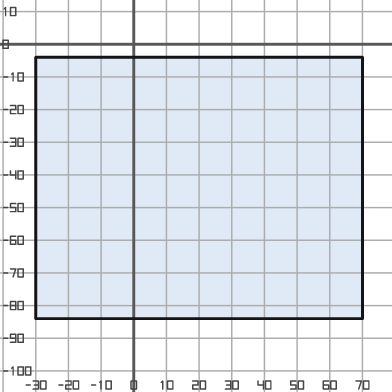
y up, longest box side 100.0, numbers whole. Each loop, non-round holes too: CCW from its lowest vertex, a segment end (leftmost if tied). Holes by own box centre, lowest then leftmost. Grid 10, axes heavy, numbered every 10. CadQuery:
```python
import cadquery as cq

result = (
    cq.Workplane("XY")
    .moveTo(-30.0, -84.0)
    .lineTo(70.0, -84.0)
    .lineTo(70.0, -4.0)
    .lineTo(-30.0, -4.0)
    .close()
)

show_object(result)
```